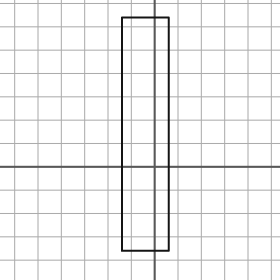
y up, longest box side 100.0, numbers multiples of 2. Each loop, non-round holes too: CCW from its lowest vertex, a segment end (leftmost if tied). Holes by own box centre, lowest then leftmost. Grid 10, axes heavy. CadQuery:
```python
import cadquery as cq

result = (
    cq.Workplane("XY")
    .moveTo(-14.0, -36.0)
    .lineTo(6.0, -36.0)
    .lineTo(6.0, 64.0)
    .lineTo(-14.0, 64.0)
    .close()
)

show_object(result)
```